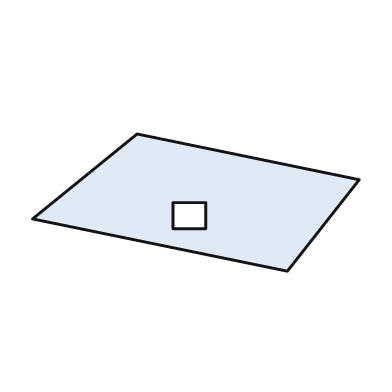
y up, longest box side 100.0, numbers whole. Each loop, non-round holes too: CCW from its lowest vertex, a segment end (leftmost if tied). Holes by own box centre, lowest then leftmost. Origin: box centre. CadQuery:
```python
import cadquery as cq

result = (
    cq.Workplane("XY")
    .moveTo(28.0, -21.0)
    .lineTo(50.0, 7.0)
    .lineTo(-18.0, 21.0)
    .lineTo(-50.0, -5.0)
    .close()
    .moveTo(-7.0, -8.0)
    .lineTo(3.0, -8.0)
    .lineTo(3.0, 0.0)
    .lineTo(-7.0, 0.0)
    .close()
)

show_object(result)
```